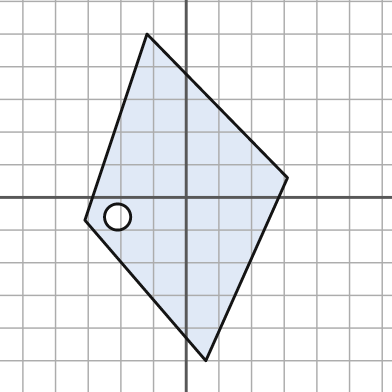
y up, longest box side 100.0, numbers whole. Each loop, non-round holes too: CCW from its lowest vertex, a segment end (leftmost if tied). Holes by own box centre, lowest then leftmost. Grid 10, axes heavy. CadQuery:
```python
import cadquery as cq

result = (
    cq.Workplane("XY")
    .moveTo(6.0, -50.0)
    .lineTo(31.0, 6.0)
    .lineTo(-12.0, 50.0)
    .lineTo(-31.0, -7.0)
    .close()
    .moveTo(-21.0, -6.0)
    .circle(4.0)
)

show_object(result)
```